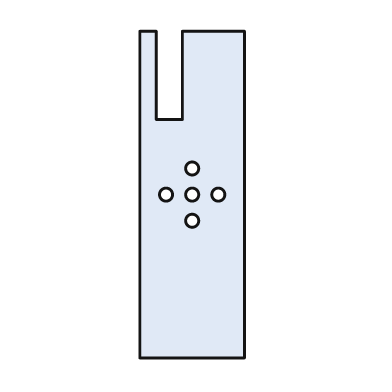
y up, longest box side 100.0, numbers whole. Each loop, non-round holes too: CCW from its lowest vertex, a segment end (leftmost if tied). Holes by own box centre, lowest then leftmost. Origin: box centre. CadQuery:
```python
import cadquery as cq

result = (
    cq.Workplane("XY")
    .moveTo(-16.0, -50.0)
    .lineTo(16.0, -50.0)
    .lineTo(16.0, 50.0)
    .lineTo(-3.0, 50.0)
    .lineTo(-3.0, 23.0)
    .lineTo(-11.0, 23.0)
    .lineTo(-11.0, 50.0)
    .lineTo(-16.0, 50.0)
    .close()
    .moveTo(0.0, -8.0)
    .circle(2.0)
    .moveTo(-8.0, 0.0)
    .circle(2.0)
    .moveTo(0.0, 0.0)
    .circle(2.0)
    .moveTo(8.0, 0.0)
    .circle(2.0)
    .moveTo(0.0, 8.0)
    .circle(2.0)
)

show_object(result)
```